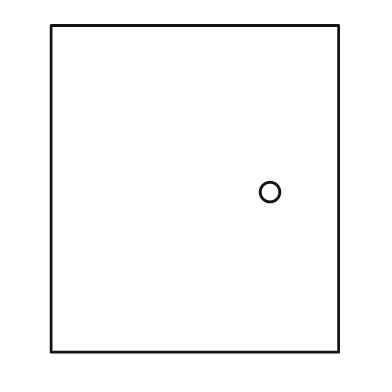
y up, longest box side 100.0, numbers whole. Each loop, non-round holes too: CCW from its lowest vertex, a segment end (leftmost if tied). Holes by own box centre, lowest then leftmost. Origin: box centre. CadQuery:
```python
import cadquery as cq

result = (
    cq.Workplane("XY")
    .moveTo(-44.0, -50.0)
    .lineTo(44.0, -50.0)
    .lineTo(44.0, 50.0)
    .lineTo(-44.0, 50.0)
    .close()
    .moveTo(23.0, -1.0)
    .circle(3.0)
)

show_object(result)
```